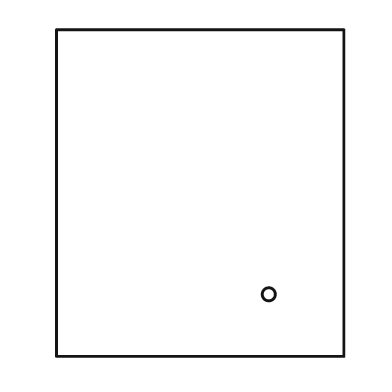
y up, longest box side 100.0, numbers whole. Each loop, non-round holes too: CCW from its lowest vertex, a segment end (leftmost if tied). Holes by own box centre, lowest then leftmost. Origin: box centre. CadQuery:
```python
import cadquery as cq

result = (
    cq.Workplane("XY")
    .moveTo(-44.0, -50.0)
    .lineTo(44.0, -50.0)
    .lineTo(44.0, 50.0)
    .lineTo(-44.0, 50.0)
    .close()
    .moveTo(21.0, -31.0)
    .circle(2.0)
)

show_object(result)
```